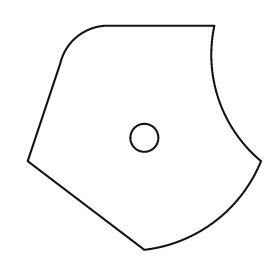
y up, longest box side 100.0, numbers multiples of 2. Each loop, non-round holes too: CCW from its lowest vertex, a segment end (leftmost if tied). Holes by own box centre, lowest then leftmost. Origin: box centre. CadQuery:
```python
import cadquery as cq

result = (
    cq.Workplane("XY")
    .moveTo(0.0, -48.0)
    .threePointArc((30.0, -36.0), (50.0, -10.0))
    .threePointArc((32.0, 16.0), (30.0, 48.0))
    .lineTo(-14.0, 48.0)
    .threePointArc((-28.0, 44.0), (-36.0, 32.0))
    .lineTo(-50.0, -10.0)
    .close()
    .moveTo(0.0, 0.0)
    .circle(6.0)
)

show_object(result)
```